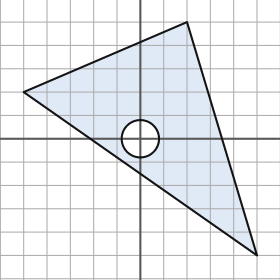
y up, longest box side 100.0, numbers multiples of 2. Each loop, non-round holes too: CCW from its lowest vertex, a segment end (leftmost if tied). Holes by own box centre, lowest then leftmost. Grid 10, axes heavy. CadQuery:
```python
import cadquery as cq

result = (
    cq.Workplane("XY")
    .moveTo(50.0, -50.0)
    .lineTo(20.0, 50.0)
    .lineTo(-50.0, 20.0)
    .close()
    .moveTo(0.0, 0.0)
    .circle(8.0)
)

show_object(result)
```